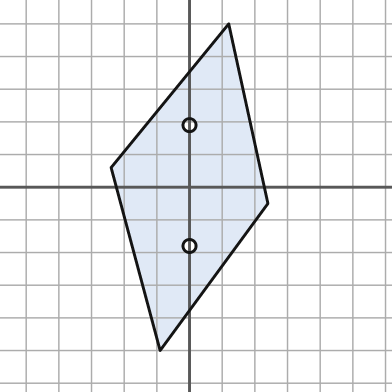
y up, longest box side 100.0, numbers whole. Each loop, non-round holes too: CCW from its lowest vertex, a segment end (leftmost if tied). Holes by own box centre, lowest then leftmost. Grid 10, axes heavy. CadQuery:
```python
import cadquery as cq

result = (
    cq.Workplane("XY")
    .moveTo(-9.0, -50.0)
    .lineTo(24.0, -5.0)
    .lineTo(12.0, 50.0)
    .lineTo(-24.0, 6.0)
    .close()
    .moveTo(0.0, -18.0)
    .circle(2.0)
    .moveTo(0.0, 19.0)
    .circle(2.0)
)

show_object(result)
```